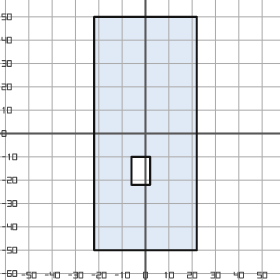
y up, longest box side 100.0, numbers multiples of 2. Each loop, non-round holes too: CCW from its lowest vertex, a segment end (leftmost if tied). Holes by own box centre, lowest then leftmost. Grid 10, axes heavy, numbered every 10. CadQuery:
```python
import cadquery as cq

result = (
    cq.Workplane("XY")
    .moveTo(-22.0, -50.0)
    .lineTo(22.0, -50.0)
    .lineTo(22.0, 50.0)
    .lineTo(-22.0, 50.0)
    .close()
    .moveTo(-6.0, -22.0)
    .lineTo(2.0, -22.0)
    .lineTo(2.0, -10.0)
    .lineTo(-6.0, -10.0)
    .close()
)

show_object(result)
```